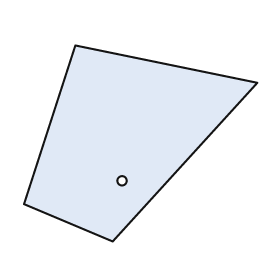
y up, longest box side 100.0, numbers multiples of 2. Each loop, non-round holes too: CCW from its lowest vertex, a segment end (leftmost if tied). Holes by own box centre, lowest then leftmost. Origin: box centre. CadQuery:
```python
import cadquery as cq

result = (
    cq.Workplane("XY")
    .moveTo(-12.0, -42.0)
    .lineTo(50.0, 26.0)
    .lineTo(-28.0, 42.0)
    .lineTo(-50.0, -26.0)
    .close()
    .moveTo(-8.0, -16.0)
    .circle(2.0)
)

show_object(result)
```